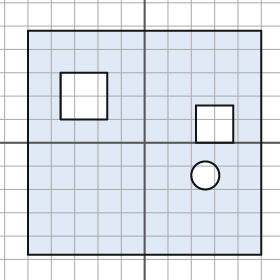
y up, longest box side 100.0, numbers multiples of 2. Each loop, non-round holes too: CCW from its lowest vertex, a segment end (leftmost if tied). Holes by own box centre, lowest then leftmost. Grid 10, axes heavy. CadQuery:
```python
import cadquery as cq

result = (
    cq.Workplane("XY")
    .moveTo(-50.0, -48.0)
    .lineTo(50.0, -48.0)
    .lineTo(50.0, 48.0)
    .lineTo(-50.0, 48.0)
    .close()
    .moveTo(26.0, -14.0)
    .circle(6.0)
    .moveTo(22.0, 0.0)
    .lineTo(38.0, 0.0)
    .lineTo(38.0, 16.0)
    .lineTo(22.0, 16.0)
    .close()
    .moveTo(-36.0, 10.0)
    .lineTo(-16.0, 10.0)
    .lineTo(-16.0, 30.0)
    .lineTo(-36.0, 30.0)
    .close()
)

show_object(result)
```